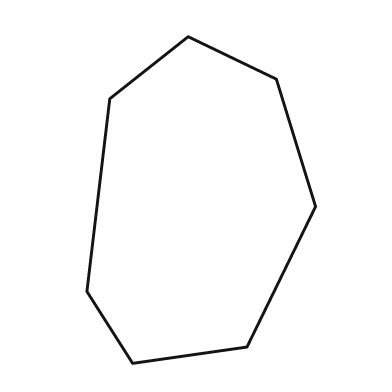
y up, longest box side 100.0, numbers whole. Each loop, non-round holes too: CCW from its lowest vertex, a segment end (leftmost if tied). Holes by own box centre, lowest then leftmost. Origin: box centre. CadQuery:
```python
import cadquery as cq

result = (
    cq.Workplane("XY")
    .moveTo(-21.0, -50.0)
    .lineTo(14.0, -45.0)
    .lineTo(35.0, -2.0)
    .lineTo(23.0, 37.0)
    .lineTo(-4.0, 50.0)
    .lineTo(-28.0, 31.0)
    .lineTo(-35.0, -28.0)
    .close()
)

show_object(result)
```